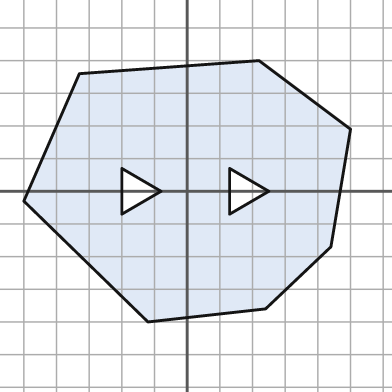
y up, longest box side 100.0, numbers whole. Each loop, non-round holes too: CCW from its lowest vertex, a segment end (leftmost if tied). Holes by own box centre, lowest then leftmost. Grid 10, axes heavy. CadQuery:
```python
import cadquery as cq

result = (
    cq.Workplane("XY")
    .moveTo(-12.0, -40.0)
    .lineTo(24.0, -36.0)
    .lineTo(44.0, -17.0)
    .lineTo(50.0, 19.0)
    .lineTo(22.0, 40.0)
    .lineTo(-33.0, 36.0)
    .lineTo(-50.0, -3.0)
    .close()
    .moveTo(-20.0, -7.0)
    .lineTo(-8.0, 0.0)
    .lineTo(-20.0, 7.0)
    .close()
    .moveTo(13.0, -7.0)
    .lineTo(25.0, 0.0)
    .lineTo(13.0, 7.0)
    .close()
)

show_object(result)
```